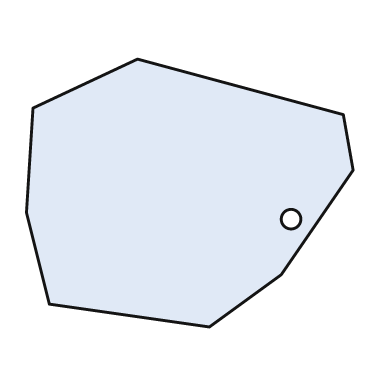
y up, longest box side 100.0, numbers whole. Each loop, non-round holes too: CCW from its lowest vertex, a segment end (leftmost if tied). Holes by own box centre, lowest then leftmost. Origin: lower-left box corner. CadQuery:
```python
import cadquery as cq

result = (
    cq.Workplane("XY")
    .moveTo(56.0, 0.0)
    .lineTo(78.0, 16.0)
    .lineTo(100.0, 48.0)
    .lineTo(97.0, 65.0)
    .lineTo(34.0, 82.0)
    .lineTo(2.0, 67.0)
    .lineTo(0.0, 35.0)
    .lineTo(7.0, 7.0)
    .close()
    .moveTo(81.0, 33.0)
    .circle(3.0)
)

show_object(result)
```